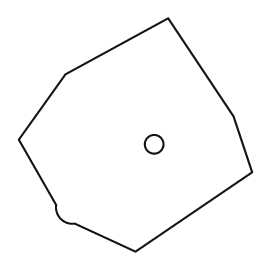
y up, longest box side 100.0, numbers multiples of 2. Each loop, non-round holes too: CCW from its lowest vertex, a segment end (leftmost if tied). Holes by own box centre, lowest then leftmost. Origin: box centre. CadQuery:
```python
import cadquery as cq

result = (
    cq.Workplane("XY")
    .moveTo(0.0, -50.0)
    .lineTo(50.0, -16.0)
    .lineTo(42.0, 8.0)
    .lineTo(14.0, 50.0)
    .lineTo(-30.0, 26.0)
    .lineTo(-50.0, -2.0)
    .lineTo(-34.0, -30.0)
    .threePointArc((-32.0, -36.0), (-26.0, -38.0))
    .close()
    .moveTo(8.0, -4.0)
    .circle(4.0)
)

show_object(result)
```